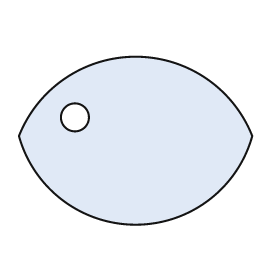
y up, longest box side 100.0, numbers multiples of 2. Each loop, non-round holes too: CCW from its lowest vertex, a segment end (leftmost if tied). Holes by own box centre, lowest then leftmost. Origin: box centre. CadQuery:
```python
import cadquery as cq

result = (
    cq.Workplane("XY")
    .moveTo(-50.0, 2.0)
    .threePointArc((0.0, -36.0), (50.0, 2.0))
    .threePointArc((0.0, 36.0), (-50.0, 2.0))
    .close()
    .moveTo(-26.0, 10.0)
    .circle(6.0)
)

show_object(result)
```